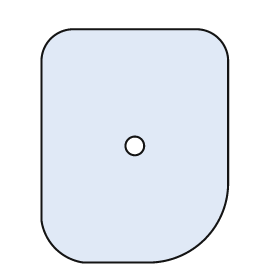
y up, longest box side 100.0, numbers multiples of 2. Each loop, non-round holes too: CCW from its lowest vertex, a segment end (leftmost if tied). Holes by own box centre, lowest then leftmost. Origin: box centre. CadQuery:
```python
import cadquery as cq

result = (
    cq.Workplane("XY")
    .moveTo(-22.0, -50.0)
    .lineTo(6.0, -50.0)
    .threePointArc((30.0, -40.0), (40.0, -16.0))
    .lineTo(40.0, 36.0)
    .threePointArc((36.0, 46.0), (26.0, 50.0))
    .lineTo(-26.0, 50.0)
    .threePointArc((-36.0, 46.0), (-40.0, 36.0))
    .lineTo(-40.0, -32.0)
    .threePointArc((-34.0, -44.0), (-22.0, -50.0))
    .close()
    .moveTo(0.0, 0.0)
    .circle(4.0)
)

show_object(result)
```